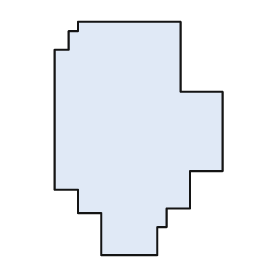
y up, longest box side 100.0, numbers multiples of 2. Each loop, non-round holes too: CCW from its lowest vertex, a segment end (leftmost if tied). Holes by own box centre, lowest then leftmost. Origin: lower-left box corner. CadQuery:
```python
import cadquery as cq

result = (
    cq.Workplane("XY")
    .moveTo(20.0, 0.0)
    .lineTo(44.0, 0.0)
    .lineTo(44.0, 12.0)
    .lineTo(48.0, 12.0)
    .lineTo(48.0, 20.0)
    .lineTo(58.0, 20.0)
    .lineTo(58.0, 36.0)
    .lineTo(72.0, 36.0)
    .lineTo(72.0, 70.0)
    .lineTo(54.0, 70.0)
    .lineTo(54.0, 100.0)
    .lineTo(10.0, 100.0)
    .lineTo(10.0, 96.0)
    .lineTo(6.0, 96.0)
    .lineTo(6.0, 88.0)
    .lineTo(0.0, 88.0)
    .lineTo(0.0, 28.0)
    .lineTo(10.0, 28.0)
    .lineTo(10.0, 18.0)
    .lineTo(20.0, 18.0)
    .close()
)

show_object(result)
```